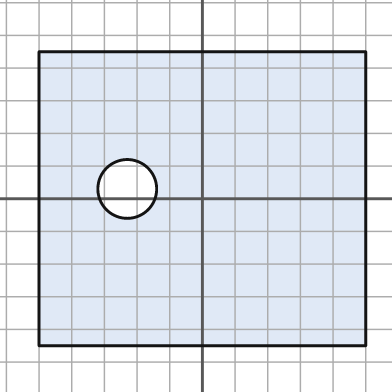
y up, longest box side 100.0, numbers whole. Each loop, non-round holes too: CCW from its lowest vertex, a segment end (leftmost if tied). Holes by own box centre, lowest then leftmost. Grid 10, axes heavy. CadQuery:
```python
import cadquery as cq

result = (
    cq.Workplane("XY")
    .moveTo(-50.0, -45.0)
    .lineTo(50.0, -45.0)
    .lineTo(50.0, 45.0)
    .lineTo(-50.0, 45.0)
    .close()
    .moveTo(-23.0, 3.0)
    .circle(9.0)
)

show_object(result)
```